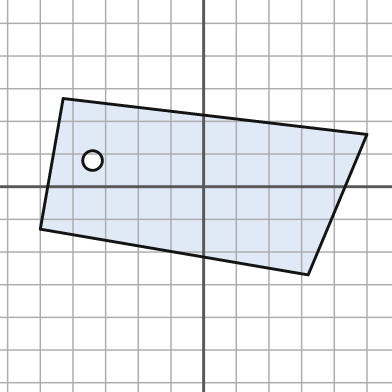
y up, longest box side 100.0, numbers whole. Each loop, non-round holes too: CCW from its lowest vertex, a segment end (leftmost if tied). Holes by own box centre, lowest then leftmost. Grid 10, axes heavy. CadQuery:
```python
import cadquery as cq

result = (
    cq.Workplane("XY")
    .moveTo(32.0, -27.0)
    .lineTo(50.0, 16.0)
    .lineTo(-43.0, 27.0)
    .lineTo(-50.0, -13.0)
    .close()
    .moveTo(-34.0, 8.0)
    .circle(3.0)
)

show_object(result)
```